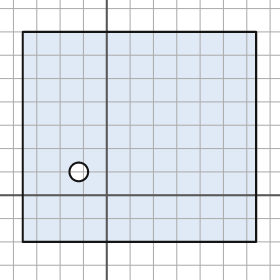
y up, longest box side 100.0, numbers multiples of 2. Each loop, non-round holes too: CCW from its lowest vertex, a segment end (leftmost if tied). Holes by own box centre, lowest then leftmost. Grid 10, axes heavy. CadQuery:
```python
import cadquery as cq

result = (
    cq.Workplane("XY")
    .moveTo(-36.0, -20.0)
    .lineTo(64.0, -20.0)
    .lineTo(64.0, 70.0)
    .lineTo(-36.0, 70.0)
    .close()
    .moveTo(-12.0, 10.0)
    .circle(4.0)
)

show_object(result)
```